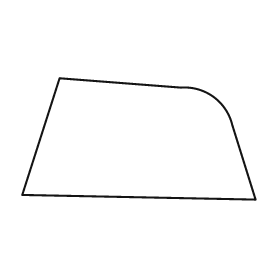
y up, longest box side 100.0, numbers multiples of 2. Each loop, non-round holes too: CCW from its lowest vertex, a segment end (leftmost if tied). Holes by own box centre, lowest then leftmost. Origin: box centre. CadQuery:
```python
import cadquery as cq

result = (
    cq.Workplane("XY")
    .moveTo(50.0, -26.0)
    .lineTo(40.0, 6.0)
    .threePointArc((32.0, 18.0), (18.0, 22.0))
    .lineTo(-34.0, 26.0)
    .lineTo(-50.0, -24.0)
    .close()
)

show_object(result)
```